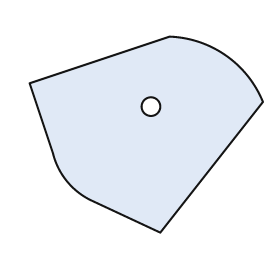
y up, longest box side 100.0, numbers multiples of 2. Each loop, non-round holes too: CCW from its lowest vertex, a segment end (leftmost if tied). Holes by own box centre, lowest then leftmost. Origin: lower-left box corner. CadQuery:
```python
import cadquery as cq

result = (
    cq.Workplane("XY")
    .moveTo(56.0, 0.0)
    .lineTo(100.0, 56.0)
    .threePointArc((84.0, 76.0), (60.0, 84.0))
    .lineTo(0.0, 64.0)
    .lineTo(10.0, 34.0)
    .threePointArc((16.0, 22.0), (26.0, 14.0))
    .close()
    .moveTo(52.0, 54.0)
    .circle(4.0)
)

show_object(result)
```